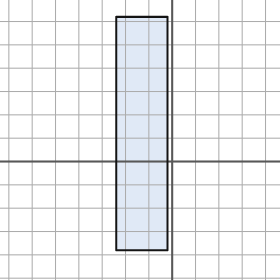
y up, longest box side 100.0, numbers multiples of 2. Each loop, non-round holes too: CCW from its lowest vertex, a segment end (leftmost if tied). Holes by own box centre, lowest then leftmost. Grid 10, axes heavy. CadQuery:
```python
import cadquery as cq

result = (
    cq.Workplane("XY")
    .moveTo(-24.0, -38.0)
    .lineTo(-2.0, -38.0)
    .lineTo(-2.0, 62.0)
    .lineTo(-24.0, 62.0)
    .close()
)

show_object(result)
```